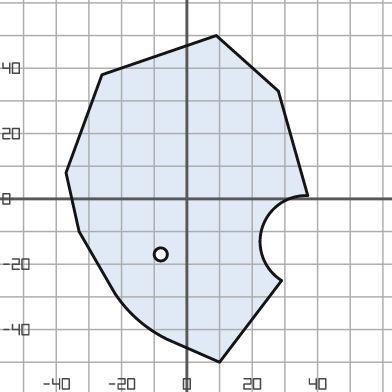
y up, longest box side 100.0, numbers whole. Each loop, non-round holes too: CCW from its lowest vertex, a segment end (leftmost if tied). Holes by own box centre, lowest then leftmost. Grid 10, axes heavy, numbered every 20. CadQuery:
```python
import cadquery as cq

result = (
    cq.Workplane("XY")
    .moveTo(10.0, -50.0)
    .lineTo(29.0, -25.0)
    .threePointArc((23.0, -9.0), (37.0, 1.0))
    .lineTo(28.0, 33.0)
    .lineTo(9.0, 50.0)
    .lineTo(-26.0, 38.0)
    .lineTo(-37.0, 8.0)
    .lineTo(-33.0, -10.0)
    .lineTo(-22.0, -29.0)
    .threePointArc((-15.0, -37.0), (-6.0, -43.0))
    .close()
    .moveTo(-8.0, -17.0)
    .circle(2.0)
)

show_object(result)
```